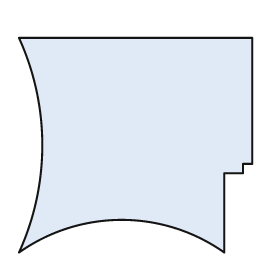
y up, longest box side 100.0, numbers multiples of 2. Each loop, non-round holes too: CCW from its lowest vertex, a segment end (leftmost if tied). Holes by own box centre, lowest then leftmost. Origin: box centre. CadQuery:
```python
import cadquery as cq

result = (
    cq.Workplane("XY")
    .moveTo(-50.0, -46.0)
    .threePointArc((-6.0, -32.0), (38.0, -46.0))
    .lineTo(38.0, -12.0)
    .lineTo(46.0, -12.0)
    .lineTo(46.0, -8.0)
    .lineTo(50.0, -8.0)
    .lineTo(50.0, 46.0)
    .lineTo(-50.0, 46.0)
    .threePointArc((-40.0, 0.0), (-50.0, -46.0))
    .close()
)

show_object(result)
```